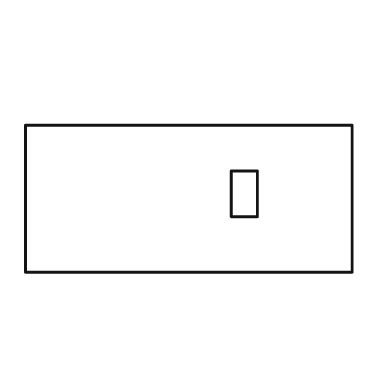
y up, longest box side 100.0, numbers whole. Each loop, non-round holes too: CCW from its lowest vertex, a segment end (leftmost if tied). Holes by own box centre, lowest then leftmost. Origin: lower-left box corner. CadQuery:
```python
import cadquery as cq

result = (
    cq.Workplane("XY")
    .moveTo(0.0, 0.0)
    .lineTo(100.0, 0.0)
    .lineTo(100.0, 45.0)
    .lineTo(0.0, 45.0)
    .close()
    .moveTo(63.0, 17.0)
    .lineTo(71.0, 17.0)
    .lineTo(71.0, 31.0)
    .lineTo(63.0, 31.0)
    .close()
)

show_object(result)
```